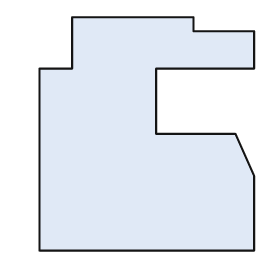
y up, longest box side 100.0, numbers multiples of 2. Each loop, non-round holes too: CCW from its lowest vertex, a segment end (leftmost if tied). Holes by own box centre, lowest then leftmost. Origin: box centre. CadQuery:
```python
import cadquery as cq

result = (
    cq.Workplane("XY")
    .moveTo(-46.0, -50.0)
    .lineTo(46.0, -50.0)
    .lineTo(46.0, -18.0)
    .lineTo(38.0, 0.0)
    .lineTo(4.0, 0.0)
    .lineTo(4.0, 28.0)
    .lineTo(46.0, 28.0)
    .lineTo(46.0, 44.0)
    .lineTo(20.0, 44.0)
    .lineTo(20.0, 50.0)
    .lineTo(-32.0, 50.0)
    .lineTo(-32.0, 28.0)
    .lineTo(-46.0, 28.0)
    .close()
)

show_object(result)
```